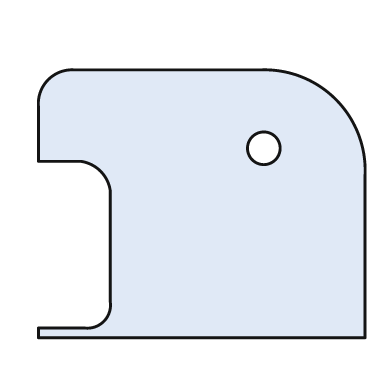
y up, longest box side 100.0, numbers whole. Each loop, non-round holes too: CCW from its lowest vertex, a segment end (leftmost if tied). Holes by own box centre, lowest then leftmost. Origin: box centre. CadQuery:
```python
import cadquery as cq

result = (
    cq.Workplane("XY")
    .moveTo(-50.0, -41.0)
    .lineTo(50.0, -41.0)
    .lineTo(50.0, 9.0)
    .threePointArc((41.0, 32.0), (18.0, 41.0))
    .lineTo(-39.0, 41.0)
    .threePointArc((-47.0, 38.0), (-50.0, 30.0))
    .lineTo(-50.0, 13.0)
    .lineTo(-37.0, 13.0)
    .threePointArc((-31.0, 10.0), (-28.0, 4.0))
    .lineTo(-28.0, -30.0)
    .threePointArc((-30.0, -36.0), (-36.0, -38.0))
    .lineTo(-50.0, -38.0)
    .close()
    .moveTo(19.0, 17.0)
    .circle(5.0)
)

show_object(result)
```